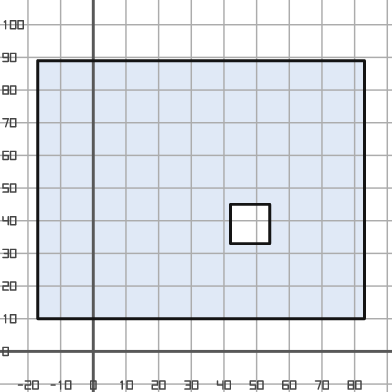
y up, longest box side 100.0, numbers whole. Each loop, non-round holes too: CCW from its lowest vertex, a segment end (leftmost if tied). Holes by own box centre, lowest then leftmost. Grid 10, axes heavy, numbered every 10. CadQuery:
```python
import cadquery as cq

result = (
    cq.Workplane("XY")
    .moveTo(-17.0, 10.0)
    .lineTo(83.0, 10.0)
    .lineTo(83.0, 89.0)
    .lineTo(-17.0, 89.0)
    .close()
    .moveTo(42.0, 33.0)
    .lineTo(54.0, 33.0)
    .lineTo(54.0, 45.0)
    .lineTo(42.0, 45.0)
    .close()
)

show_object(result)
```